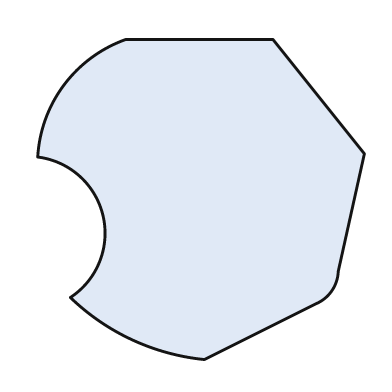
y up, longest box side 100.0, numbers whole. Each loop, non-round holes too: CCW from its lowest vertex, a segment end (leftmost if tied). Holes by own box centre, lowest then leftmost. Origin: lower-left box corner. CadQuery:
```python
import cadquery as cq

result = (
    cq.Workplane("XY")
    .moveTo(51.0, 0.0)
    .lineTo(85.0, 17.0)
    .threePointArc((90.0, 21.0), (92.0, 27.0))
    .lineTo(100.0, 63.0)
    .lineTo(72.0, 98.0)
    .lineTo(27.0, 98.0)
    .threePointArc((8.0, 84.0), (0.0, 62.0))
    .threePointArc((20.0, 44.0), (10.0, 19.0))
    .threePointArc((29.0, 6.0), (51.0, 0.0))
    .close()
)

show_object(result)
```